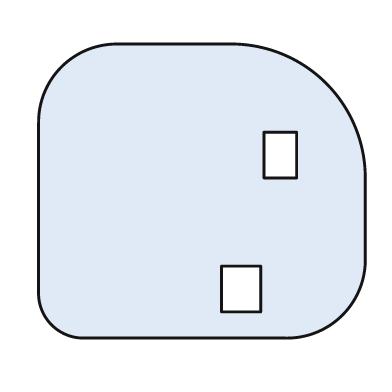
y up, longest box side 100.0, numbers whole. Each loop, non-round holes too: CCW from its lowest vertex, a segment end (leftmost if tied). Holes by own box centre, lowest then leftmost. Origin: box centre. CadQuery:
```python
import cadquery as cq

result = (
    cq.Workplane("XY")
    .moveTo(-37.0, -45.0)
    .lineTo(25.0, -45.0)
    .threePointArc((43.0, -38.0), (50.0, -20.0))
    .lineTo(50.0, 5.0)
    .threePointArc((38.0, 33.0), (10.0, 45.0))
    .lineTo(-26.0, 45.0)
    .threePointArc((-43.0, 38.0), (-50.0, 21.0))
    .lineTo(-50.0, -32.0)
    .threePointArc((-46.0, -41.0), (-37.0, -45.0))
    .close()
    .moveTo(6.0, -37.0)
    .lineTo(18.0, -37.0)
    .lineTo(18.0, -23.0)
    .lineTo(6.0, -23.0)
    .close()
    .moveTo(19.0, 4.0)
    .lineTo(29.0, 4.0)
    .lineTo(29.0, 18.0)
    .lineTo(19.0, 18.0)
    .close()
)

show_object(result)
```